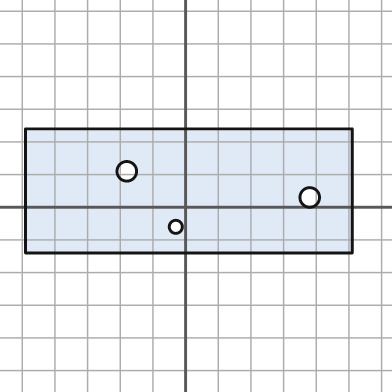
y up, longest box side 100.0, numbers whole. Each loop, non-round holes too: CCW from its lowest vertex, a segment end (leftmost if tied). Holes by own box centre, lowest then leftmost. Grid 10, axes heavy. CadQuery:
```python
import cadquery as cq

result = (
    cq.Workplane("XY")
    .moveTo(-49.0, -14.0)
    .lineTo(51.0, -14.0)
    .lineTo(51.0, 24.0)
    .lineTo(-49.0, 24.0)
    .close()
    .moveTo(-3.0, -6.0)
    .circle(2.0)
    .moveTo(38.0, 3.0)
    .circle(3.0)
    .moveTo(-18.0, 11.0)
    .circle(3.0)
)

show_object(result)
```